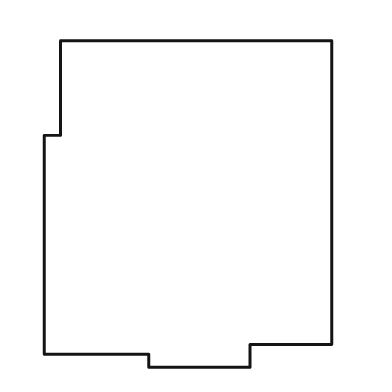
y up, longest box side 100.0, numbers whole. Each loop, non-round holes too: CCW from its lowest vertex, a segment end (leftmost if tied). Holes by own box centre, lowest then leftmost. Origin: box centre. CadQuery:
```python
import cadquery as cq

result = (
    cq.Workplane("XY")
    .moveTo(-12.0, -50.0)
    .lineTo(19.0, -50.0)
    .lineTo(19.0, -43.0)
    .lineTo(44.0, -43.0)
    .lineTo(44.0, 50.0)
    .lineTo(-39.0, 50.0)
    .lineTo(-39.0, 21.0)
    .lineTo(-44.0, 21.0)
    .lineTo(-44.0, -46.0)
    .lineTo(-12.0, -46.0)
    .close()
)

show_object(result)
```